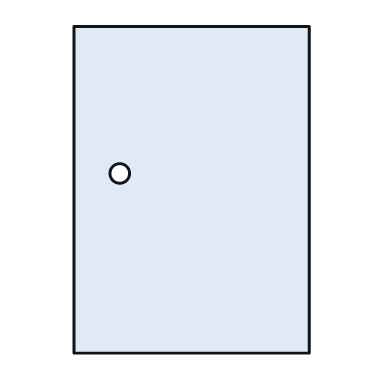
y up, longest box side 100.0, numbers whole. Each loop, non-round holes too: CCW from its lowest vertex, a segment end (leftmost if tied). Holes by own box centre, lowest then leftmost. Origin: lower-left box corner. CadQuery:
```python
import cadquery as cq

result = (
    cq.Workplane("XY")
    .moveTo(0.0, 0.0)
    .lineTo(72.0, 0.0)
    .lineTo(72.0, 100.0)
    .lineTo(0.0, 100.0)
    .close()
    .moveTo(14.0, 55.0)
    .circle(3.0)
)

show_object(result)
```